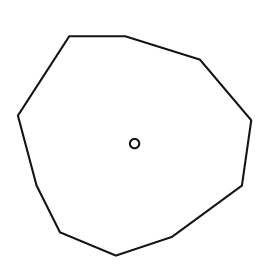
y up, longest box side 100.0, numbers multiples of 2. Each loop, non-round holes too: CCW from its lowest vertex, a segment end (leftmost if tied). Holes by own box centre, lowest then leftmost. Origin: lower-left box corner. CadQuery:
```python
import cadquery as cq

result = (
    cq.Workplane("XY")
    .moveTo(42.0, 0.0)
    .lineTo(66.0, 8.0)
    .lineTo(96.0, 30.0)
    .lineTo(100.0, 58.0)
    .lineTo(78.0, 84.0)
    .lineTo(46.0, 94.0)
    .lineTo(22.0, 94.0)
    .lineTo(0.0, 60.0)
    .lineTo(8.0, 30.0)
    .lineTo(18.0, 10.0)
    .close()
    .moveTo(50.0, 48.0)
    .circle(2.0)
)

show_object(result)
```